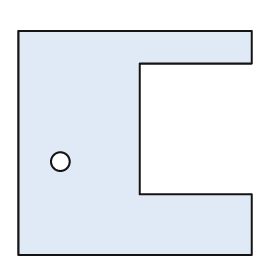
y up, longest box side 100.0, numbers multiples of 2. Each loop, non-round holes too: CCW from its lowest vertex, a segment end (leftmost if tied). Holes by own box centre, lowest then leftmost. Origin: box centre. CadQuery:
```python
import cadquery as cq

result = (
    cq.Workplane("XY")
    .moveTo(-50.0, -48.0)
    .lineTo(50.0, -48.0)
    .lineTo(50.0, -22.0)
    .lineTo(2.0, -22.0)
    .lineTo(2.0, 34.0)
    .lineTo(50.0, 34.0)
    .lineTo(50.0, 48.0)
    .lineTo(-50.0, 48.0)
    .close()
    .moveTo(-32.0, -8.0)
    .circle(4.0)
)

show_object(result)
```